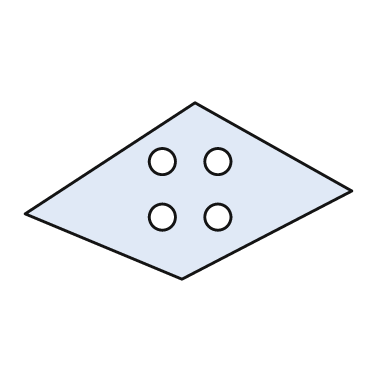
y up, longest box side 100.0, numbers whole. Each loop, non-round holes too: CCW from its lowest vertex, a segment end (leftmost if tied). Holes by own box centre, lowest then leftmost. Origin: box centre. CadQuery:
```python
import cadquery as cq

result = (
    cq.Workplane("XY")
    .moveTo(-2.0, -27.0)
    .lineTo(50.0, 0.0)
    .lineTo(2.0, 27.0)
    .lineTo(-50.0, -7.0)
    .close()
    .moveTo(-8.0, -8.0)
    .circle(4.0)
    .moveTo(9.0, -8.0)
    .circle(4.0)
    .moveTo(-8.0, 9.0)
    .circle(4.0)
    .moveTo(9.0, 9.0)
    .circle(4.0)
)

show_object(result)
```